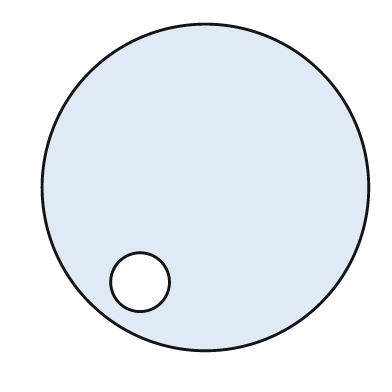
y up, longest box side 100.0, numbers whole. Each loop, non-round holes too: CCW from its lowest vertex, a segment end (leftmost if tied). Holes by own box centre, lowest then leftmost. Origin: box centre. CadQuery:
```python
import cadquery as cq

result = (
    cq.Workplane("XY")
    .moveTo(0.0, 0.0)
    .circle(50.0)
    .moveTo(-20.0, -29.0)
    .circle(9.0)
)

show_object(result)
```